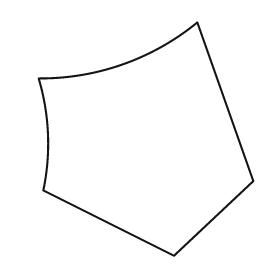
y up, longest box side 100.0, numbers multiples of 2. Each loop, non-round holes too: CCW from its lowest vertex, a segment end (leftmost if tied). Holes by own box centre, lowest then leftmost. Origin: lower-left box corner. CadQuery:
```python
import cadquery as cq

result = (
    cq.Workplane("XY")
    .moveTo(58.0, 0.0)
    .lineTo(92.0, 32.0)
    .lineTo(68.0, 100.0)
    .threePointArc((36.0, 82.0), (0.0, 76.0))
    .threePointArc((4.0, 52.0), (2.0, 28.0))
    .close()
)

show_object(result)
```